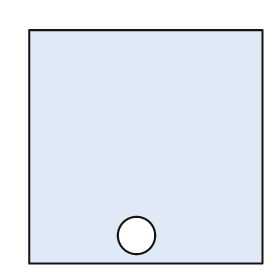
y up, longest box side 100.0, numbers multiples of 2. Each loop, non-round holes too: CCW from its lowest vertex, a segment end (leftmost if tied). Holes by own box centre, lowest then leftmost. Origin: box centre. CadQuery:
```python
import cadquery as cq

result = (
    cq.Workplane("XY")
    .moveTo(-50.0, -50.0)
    .lineTo(50.0, -50.0)
    .lineTo(50.0, 50.0)
    .lineTo(-50.0, 50.0)
    .close()
    .moveTo(-4.0, -38.0)
    .circle(8.0)
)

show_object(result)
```